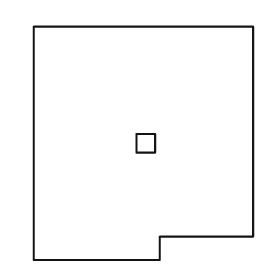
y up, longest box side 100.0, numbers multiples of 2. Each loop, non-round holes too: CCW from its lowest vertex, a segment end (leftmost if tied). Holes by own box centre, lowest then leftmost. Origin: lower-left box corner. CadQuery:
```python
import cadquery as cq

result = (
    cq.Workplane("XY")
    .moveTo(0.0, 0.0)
    .lineTo(54.0, 0.0)
    .lineTo(54.0, 10.0)
    .lineTo(94.0, 10.0)
    .lineTo(94.0, 100.0)
    .lineTo(0.0, 100.0)
    .close()
    .moveTo(44.0, 46.0)
    .lineTo(52.0, 46.0)
    .lineTo(52.0, 54.0)
    .lineTo(44.0, 54.0)
    .close()
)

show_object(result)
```